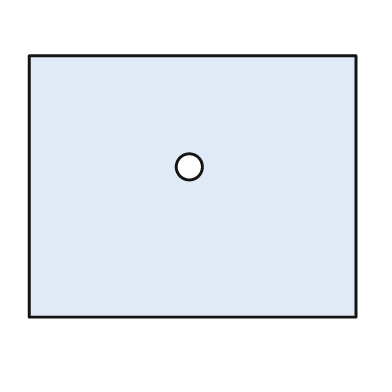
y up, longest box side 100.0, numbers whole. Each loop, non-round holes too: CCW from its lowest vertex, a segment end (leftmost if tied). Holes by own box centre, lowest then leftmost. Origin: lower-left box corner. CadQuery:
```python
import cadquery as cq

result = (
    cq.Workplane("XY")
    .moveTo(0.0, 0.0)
    .lineTo(100.0, 0.0)
    .lineTo(100.0, 80.0)
    .lineTo(0.0, 80.0)
    .close()
    .moveTo(49.0, 46.0)
    .circle(4.0)
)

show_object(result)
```